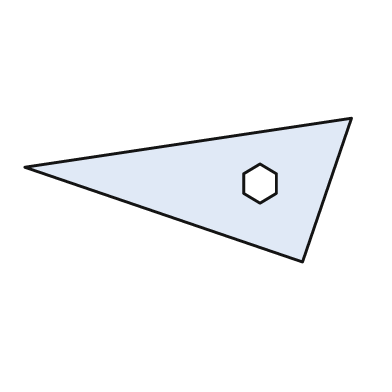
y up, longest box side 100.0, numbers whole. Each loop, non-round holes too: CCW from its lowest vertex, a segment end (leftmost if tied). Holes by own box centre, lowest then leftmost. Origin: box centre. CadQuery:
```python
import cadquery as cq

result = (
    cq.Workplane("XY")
    .moveTo(35.0, -22.0)
    .lineTo(50.0, 22.0)
    .lineTo(-50.0, 7.0)
    .close()
    .moveTo(22.0, -4.0)
    .lineTo(27.0, -1.0)
    .lineTo(27.0, 5.0)
    .lineTo(22.0, 8.0)
    .lineTo(17.0, 5.0)
    .lineTo(17.0, -1.0)
    .close()
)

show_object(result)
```